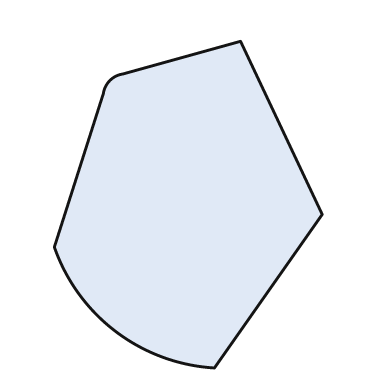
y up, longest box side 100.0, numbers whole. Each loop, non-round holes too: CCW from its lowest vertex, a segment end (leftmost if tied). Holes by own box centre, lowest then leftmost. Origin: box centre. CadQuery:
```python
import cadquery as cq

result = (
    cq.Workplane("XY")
    .moveTo(8.0, -50.0)
    .lineTo(41.0, -3.0)
    .lineTo(16.0, 50.0)
    .lineTo(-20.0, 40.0)
    .threePointArc((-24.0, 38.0), (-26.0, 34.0))
    .lineTo(-41.0, -13.0)
    .threePointArc((-22.0, -39.0), (8.0, -50.0))
    .close()
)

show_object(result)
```